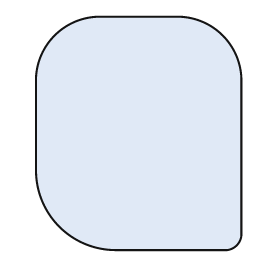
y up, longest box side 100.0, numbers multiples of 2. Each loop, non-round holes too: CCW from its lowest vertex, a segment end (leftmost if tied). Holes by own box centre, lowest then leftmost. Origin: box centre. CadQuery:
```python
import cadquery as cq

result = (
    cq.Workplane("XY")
    .moveTo(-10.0, -50.0)
    .lineTo(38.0, -50.0)
    .threePointArc((42.0, -48.0), (44.0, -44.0))
    .lineTo(44.0, 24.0)
    .threePointArc((36.0, 42.0), (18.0, 50.0))
    .lineTo(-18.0, 50.0)
    .threePointArc((-36.0, 42.0), (-44.0, 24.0))
    .lineTo(-44.0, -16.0)
    .threePointArc((-34.0, -40.0), (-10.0, -50.0))
    .close()
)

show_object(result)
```